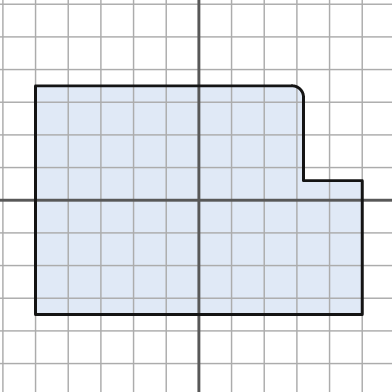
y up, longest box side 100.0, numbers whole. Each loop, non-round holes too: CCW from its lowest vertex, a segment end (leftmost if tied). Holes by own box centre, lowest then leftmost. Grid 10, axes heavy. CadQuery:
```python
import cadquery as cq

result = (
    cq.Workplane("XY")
    .moveTo(-50.0, -35.0)
    .lineTo(50.0, -35.0)
    .lineTo(50.0, 6.0)
    .lineTo(32.0, 6.0)
    .lineTo(32.0, 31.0)
    .threePointArc((31.0, 34.0), (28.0, 35.0))
    .lineTo(-50.0, 35.0)
    .close()
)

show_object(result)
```